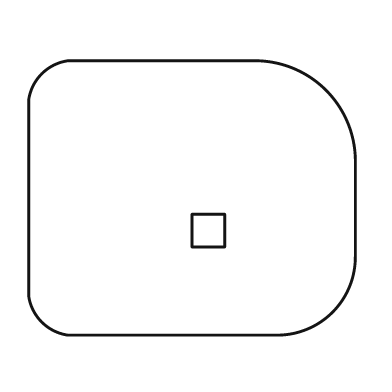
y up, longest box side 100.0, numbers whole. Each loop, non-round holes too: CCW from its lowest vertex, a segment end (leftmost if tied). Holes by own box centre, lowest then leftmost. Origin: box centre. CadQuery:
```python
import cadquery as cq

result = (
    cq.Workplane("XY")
    .moveTo(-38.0, -42.0)
    .lineTo(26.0, -42.0)
    .threePointArc((43.0, -35.0), (50.0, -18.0))
    .lineTo(50.0, 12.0)
    .threePointArc((41.0, 33.0), (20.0, 42.0))
    .lineTo(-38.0, 42.0)
    .threePointArc((-46.0, 38.0), (-50.0, 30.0))
    .lineTo(-50.0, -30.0)
    .threePointArc((-46.0, -38.0), (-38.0, -42.0))
    .close()
    .moveTo(0.0, -15.0)
    .lineTo(10.0, -15.0)
    .lineTo(10.0, -5.0)
    .lineTo(0.0, -5.0)
    .close()
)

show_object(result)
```